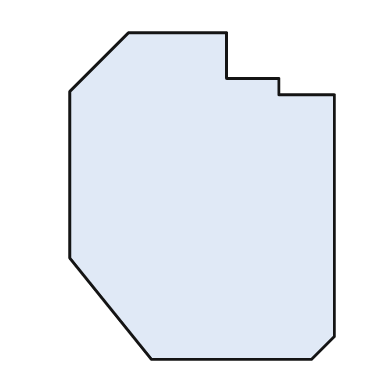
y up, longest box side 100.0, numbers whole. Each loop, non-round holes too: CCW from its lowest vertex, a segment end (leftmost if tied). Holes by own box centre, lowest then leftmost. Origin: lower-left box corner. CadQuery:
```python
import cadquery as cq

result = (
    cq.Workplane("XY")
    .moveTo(25.0, 0.0)
    .lineTo(74.0, 0.0)
    .lineTo(81.0, 7.0)
    .lineTo(81.0, 81.0)
    .lineTo(64.0, 81.0)
    .lineTo(64.0, 86.0)
    .lineTo(48.0, 86.0)
    .lineTo(48.0, 100.0)
    .lineTo(18.0, 100.0)
    .lineTo(0.0, 82.0)
    .lineTo(0.0, 31.0)
    .close()
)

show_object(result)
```